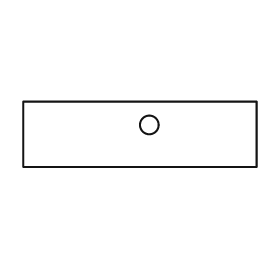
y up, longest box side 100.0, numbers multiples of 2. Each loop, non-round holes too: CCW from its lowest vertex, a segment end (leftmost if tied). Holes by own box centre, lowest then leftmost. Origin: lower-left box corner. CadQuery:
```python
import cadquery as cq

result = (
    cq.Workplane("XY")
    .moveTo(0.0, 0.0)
    .lineTo(100.0, 0.0)
    .lineTo(100.0, 28.0)
    .lineTo(0.0, 28.0)
    .close()
    .moveTo(54.0, 18.0)
    .circle(4.0)
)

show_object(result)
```